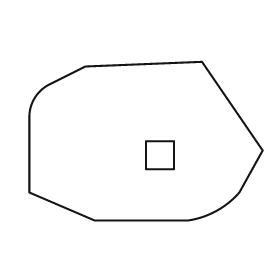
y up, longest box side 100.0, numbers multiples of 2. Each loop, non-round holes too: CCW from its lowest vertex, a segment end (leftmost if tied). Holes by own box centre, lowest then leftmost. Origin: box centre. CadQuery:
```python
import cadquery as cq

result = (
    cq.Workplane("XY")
    .moveTo(-22.0, -34.0)
    .lineTo(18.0, -34.0)
    .threePointArc((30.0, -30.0), (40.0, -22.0))
    .lineTo(50.0, -4.0)
    .lineTo(24.0, 34.0)
    .lineTo(-26.0, 32.0)
    .lineTo(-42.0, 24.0)
    .threePointArc((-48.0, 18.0), (-50.0, 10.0))
    .lineTo(-50.0, -22.0)
    .close()
    .moveTo(0.0, -12.0)
    .lineTo(12.0, -12.0)
    .lineTo(12.0, 0.0)
    .lineTo(0.0, 0.0)
    .close()
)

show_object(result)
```